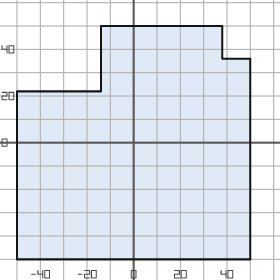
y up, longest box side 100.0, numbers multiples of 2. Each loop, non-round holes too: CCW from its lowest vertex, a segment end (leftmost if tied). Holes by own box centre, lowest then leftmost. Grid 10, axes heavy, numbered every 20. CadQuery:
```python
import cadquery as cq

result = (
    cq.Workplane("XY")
    .moveTo(-50.0, -50.0)
    .lineTo(50.0, -50.0)
    .lineTo(50.0, 36.0)
    .lineTo(38.0, 36.0)
    .lineTo(38.0, 50.0)
    .lineTo(-14.0, 50.0)
    .lineTo(-14.0, 22.0)
    .lineTo(-50.0, 22.0)
    .close()
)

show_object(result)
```